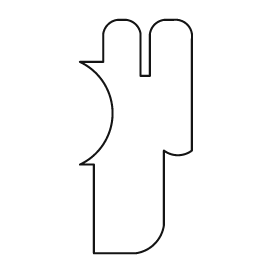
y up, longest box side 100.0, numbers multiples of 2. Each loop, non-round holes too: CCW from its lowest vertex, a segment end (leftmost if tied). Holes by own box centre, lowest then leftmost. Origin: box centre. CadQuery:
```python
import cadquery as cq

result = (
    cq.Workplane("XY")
    .moveTo(-18.0, -50.0)
    .lineTo(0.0, -50.0)
    .threePointArc((8.0, -46.0), (12.0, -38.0))
    .lineTo(12.0, -6.0)
    .threePointArc((18.0, -8.0), (24.0, -6.0))
    .lineTo(24.0, 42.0)
    .threePointArc((22.0, 48.0), (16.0, 50.0))
    .lineTo(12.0, 50.0)
    .threePointArc((8.0, 48.0), (6.0, 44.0))
    .lineTo(6.0, 26.0)
    .lineTo(2.0, 26.0)
    .lineTo(2.0, 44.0)
    .threePointArc((0.0, 48.0), (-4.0, 50.0))
    .lineTo(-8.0, 50.0)
    .threePointArc((-12.0, 48.0), (-14.0, 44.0))
    .lineTo(-14.0, 32.0)
    .lineTo(-24.0, 32.0)
    .threePointArc((-10.0, 10.0), (-24.0, -12.0))
    .lineTo(-18.0, -12.0)
    .close()
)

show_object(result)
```